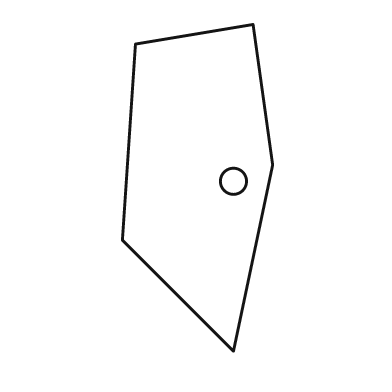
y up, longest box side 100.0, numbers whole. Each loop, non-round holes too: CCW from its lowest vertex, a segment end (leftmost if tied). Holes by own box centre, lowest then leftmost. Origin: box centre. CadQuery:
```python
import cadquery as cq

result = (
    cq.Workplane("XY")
    .moveTo(11.0, -50.0)
    .lineTo(23.0, 7.0)
    .lineTo(17.0, 50.0)
    .lineTo(-19.0, 44.0)
    .lineTo(-23.0, -16.0)
    .close()
    .moveTo(11.0, 2.0)
    .circle(4.0)
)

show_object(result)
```